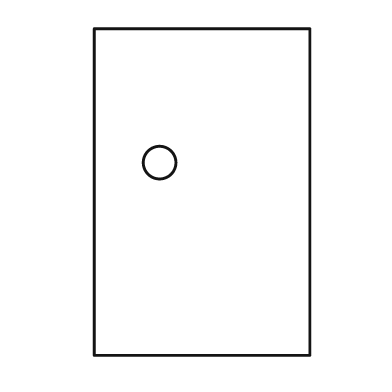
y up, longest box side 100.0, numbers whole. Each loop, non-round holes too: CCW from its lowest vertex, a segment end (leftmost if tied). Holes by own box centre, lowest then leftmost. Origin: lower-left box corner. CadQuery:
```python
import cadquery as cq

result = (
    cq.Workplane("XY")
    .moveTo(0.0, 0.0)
    .lineTo(66.0, 0.0)
    .lineTo(66.0, 100.0)
    .lineTo(0.0, 100.0)
    .close()
    .moveTo(20.0, 59.0)
    .circle(5.0)
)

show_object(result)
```